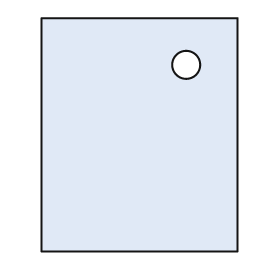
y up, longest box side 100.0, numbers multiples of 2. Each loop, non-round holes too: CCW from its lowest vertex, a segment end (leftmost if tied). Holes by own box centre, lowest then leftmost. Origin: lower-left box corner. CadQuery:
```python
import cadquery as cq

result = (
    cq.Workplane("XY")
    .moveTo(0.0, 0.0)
    .lineTo(84.0, 0.0)
    .lineTo(84.0, 100.0)
    .lineTo(0.0, 100.0)
    .close()
    .moveTo(62.0, 80.0)
    .circle(6.0)
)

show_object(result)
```